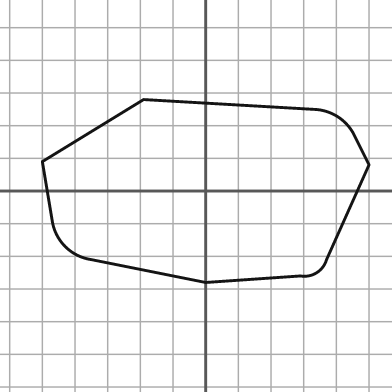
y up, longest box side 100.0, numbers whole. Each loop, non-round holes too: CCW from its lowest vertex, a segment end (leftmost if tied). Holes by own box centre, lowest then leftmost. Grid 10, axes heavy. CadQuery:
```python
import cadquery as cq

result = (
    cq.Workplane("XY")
    .moveTo(0.0, -28.0)
    .lineTo(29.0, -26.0)
    .threePointArc((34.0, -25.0), (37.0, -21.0))
    .lineTo(50.0, 8.0)
    .lineTo(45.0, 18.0)
    .threePointArc((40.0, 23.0), (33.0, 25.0))
    .lineTo(-19.0, 28.0)
    .lineTo(-50.0, 9.0)
    .lineTo(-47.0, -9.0)
    .threePointArc((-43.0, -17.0), (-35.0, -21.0))
    .close()
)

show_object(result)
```